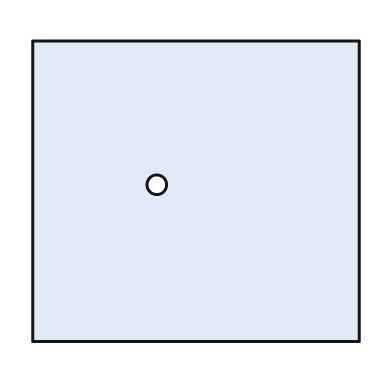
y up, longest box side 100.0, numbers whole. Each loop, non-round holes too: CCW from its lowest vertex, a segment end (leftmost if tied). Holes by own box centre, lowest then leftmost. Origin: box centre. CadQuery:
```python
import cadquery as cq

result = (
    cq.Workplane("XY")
    .moveTo(-50.0, -46.0)
    .lineTo(50.0, -46.0)
    .lineTo(50.0, 46.0)
    .lineTo(-50.0, 46.0)
    .close()
    .moveTo(-12.0, 2.0)
    .circle(3.0)
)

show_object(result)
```